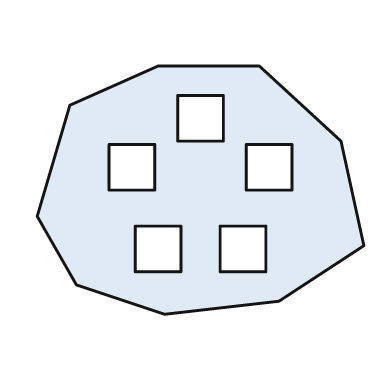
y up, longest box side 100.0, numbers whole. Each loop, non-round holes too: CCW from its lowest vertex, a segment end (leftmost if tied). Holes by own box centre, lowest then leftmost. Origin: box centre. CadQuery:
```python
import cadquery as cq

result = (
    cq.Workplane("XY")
    .moveTo(-11.0, -38.0)
    .lineTo(24.0, -34.0)
    .lineTo(50.0, -17.0)
    .lineTo(43.0, 15.0)
    .lineTo(18.0, 38.0)
    .lineTo(-13.0, 38.0)
    .lineTo(-40.0, 26.0)
    .lineTo(-50.0, -8.0)
    .lineTo(-38.0, -29.0)
    .close()
    .moveTo(-20.0, -25.0)
    .lineTo(-6.0, -25.0)
    .lineTo(-6.0, -11.0)
    .lineTo(-20.0, -11.0)
    .close()
    .moveTo(6.0, -25.0)
    .lineTo(20.0, -25.0)
    .lineTo(20.0, -11.0)
    .lineTo(6.0, -11.0)
    .close()
    .moveTo(-28.0, 0.0)
    .lineTo(-14.0, 0.0)
    .lineTo(-14.0, 14.0)
    .lineTo(-28.0, 14.0)
    .close()
    .moveTo(14.0, 0.0)
    .lineTo(28.0, 0.0)
    .lineTo(28.0, 14.0)
    .lineTo(14.0, 14.0)
    .close()
    .moveTo(-7.0, 15.0)
    .lineTo(7.0, 15.0)
    .lineTo(7.0, 29.0)
    .lineTo(-7.0, 29.0)
    .close()
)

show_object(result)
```